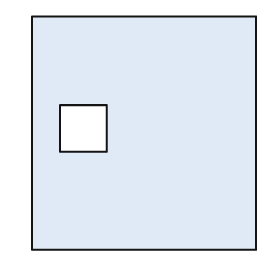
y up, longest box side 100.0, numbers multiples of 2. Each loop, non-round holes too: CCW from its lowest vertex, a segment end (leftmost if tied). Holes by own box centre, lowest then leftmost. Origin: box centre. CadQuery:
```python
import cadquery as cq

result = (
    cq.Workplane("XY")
    .moveTo(-48.0, -50.0)
    .lineTo(48.0, -50.0)
    .lineTo(48.0, 50.0)
    .lineTo(-48.0, 50.0)
    .close()
    .moveTo(-36.0, -8.0)
    .lineTo(-16.0, -8.0)
    .lineTo(-16.0, 12.0)
    .lineTo(-36.0, 12.0)
    .close()
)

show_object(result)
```